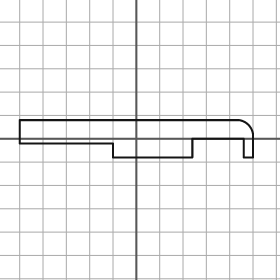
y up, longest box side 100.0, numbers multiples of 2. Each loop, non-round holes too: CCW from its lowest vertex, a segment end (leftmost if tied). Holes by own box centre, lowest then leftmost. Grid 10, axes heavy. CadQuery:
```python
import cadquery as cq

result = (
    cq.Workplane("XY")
    .moveTo(-10.0, -8.0)
    .lineTo(24.0, -8.0)
    .lineTo(24.0, 0.0)
    .lineTo(46.0, 0.0)
    .lineTo(46.0, -8.0)
    .lineTo(50.0, -8.0)
    .lineTo(50.0, 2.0)
    .threePointArc((48.0, 6.0), (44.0, 8.0))
    .lineTo(-50.0, 8.0)
    .lineTo(-50.0, -2.0)
    .lineTo(-10.0, -2.0)
    .close()
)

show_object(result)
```